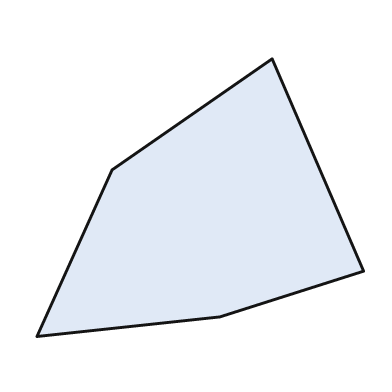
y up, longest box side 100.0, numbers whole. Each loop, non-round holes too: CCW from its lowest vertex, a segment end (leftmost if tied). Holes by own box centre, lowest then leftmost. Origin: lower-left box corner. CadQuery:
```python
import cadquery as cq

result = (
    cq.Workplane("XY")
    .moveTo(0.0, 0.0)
    .lineTo(56.0, 6.0)
    .lineTo(100.0, 20.0)
    .lineTo(72.0, 85.0)
    .lineTo(23.0, 51.0)
    .close()
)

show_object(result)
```